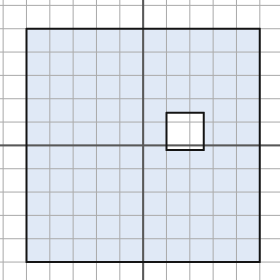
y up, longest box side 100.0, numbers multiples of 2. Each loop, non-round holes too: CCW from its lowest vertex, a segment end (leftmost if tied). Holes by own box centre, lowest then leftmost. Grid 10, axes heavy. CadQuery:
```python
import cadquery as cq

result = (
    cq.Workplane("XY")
    .moveTo(-50.0, -50.0)
    .lineTo(50.0, -50.0)
    .lineTo(50.0, 50.0)
    .lineTo(-50.0, 50.0)
    .close()
    .moveTo(10.0, -2.0)
    .lineTo(26.0, -2.0)
    .lineTo(26.0, 14.0)
    .lineTo(10.0, 14.0)
    .close()
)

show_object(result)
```